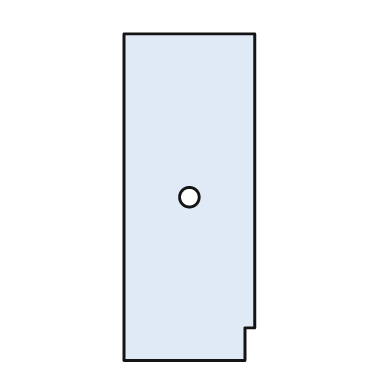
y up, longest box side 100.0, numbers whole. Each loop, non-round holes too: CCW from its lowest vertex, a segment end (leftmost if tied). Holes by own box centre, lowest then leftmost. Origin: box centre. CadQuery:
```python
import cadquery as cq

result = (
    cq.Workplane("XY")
    .moveTo(-20.0, -50.0)
    .lineTo(17.0, -50.0)
    .lineTo(17.0, -40.0)
    .lineTo(20.0, -40.0)
    .lineTo(20.0, 50.0)
    .lineTo(-20.0, 50.0)
    .close()
    .moveTo(0.0, 0.0)
    .circle(3.0)
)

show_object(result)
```